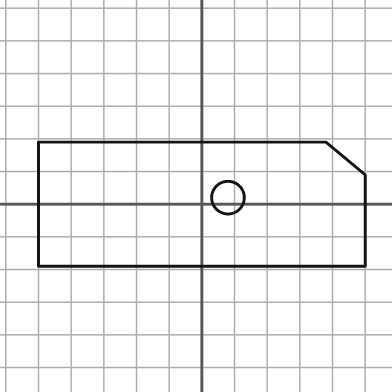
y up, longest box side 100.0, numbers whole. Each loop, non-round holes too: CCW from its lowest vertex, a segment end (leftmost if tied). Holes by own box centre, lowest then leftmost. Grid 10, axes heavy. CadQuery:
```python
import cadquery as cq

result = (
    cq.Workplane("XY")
    .moveTo(-50.0, -19.0)
    .lineTo(50.0, -19.0)
    .lineTo(50.0, 9.0)
    .lineTo(38.0, 19.0)
    .lineTo(-50.0, 19.0)
    .close()
    .moveTo(8.0, 2.0)
    .circle(5.0)
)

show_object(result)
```